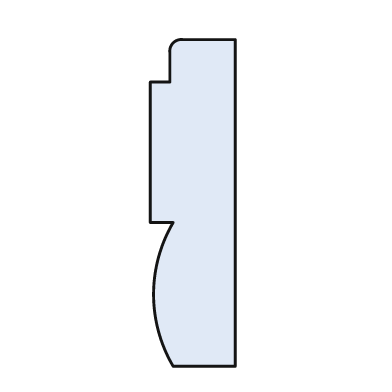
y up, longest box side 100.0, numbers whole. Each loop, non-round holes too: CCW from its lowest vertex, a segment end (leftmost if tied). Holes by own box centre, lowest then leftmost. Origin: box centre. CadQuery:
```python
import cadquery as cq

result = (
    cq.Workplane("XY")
    .moveTo(-6.0, -50.0)
    .lineTo(13.0, -50.0)
    .lineTo(13.0, 50.0)
    .lineTo(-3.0, 50.0)
    .threePointArc((-6.0, 49.0), (-7.0, 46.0))
    .lineTo(-7.0, 37.0)
    .lineTo(-13.0, 37.0)
    .lineTo(-13.0, -6.0)
    .lineTo(-6.0, -6.0)
    .threePointArc((-12.0, -28.0), (-6.0, -50.0))
    .close()
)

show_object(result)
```